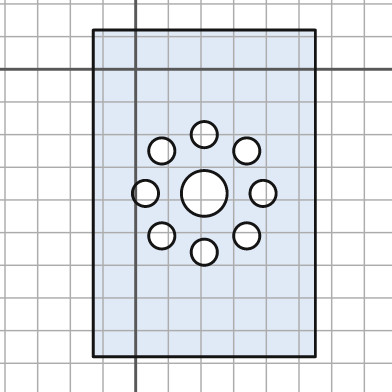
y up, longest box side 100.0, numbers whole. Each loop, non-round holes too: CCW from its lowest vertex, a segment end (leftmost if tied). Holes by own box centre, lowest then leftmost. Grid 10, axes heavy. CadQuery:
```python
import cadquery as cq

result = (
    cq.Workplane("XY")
    .moveTo(-13.0, -88.0)
    .lineTo(55.0, -88.0)
    .lineTo(55.0, 12.0)
    .lineTo(-13.0, 12.0)
    .close()
    .moveTo(21.0, -56.0)
    .circle(4.0)
    .moveTo(8.0, -51.0)
    .circle(4.0)
    .moveTo(34.0, -51.0)
    .circle(4.0)
    .moveTo(3.0, -38.0)
    .circle(4.0)
    .moveTo(21.0, -38.0)
    .circle(7.0)
    .moveTo(39.0, -38.0)
    .circle(4.0)
    .moveTo(8.0, -25.0)
    .circle(4.0)
    .moveTo(34.0, -25.0)
    .circle(4.0)
    .moveTo(21.0, -20.0)
    .circle(4.0)
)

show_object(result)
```